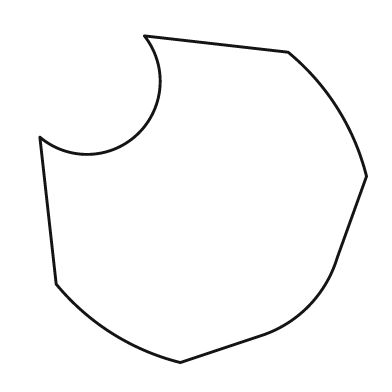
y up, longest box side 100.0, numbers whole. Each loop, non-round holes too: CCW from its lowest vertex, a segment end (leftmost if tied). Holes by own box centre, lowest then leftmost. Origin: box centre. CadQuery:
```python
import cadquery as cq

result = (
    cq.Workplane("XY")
    .moveTo(-7.0, -50.0)
    .lineTo(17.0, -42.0)
    .threePointArc((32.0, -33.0), (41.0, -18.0))
    .lineTo(50.0, 7.0)
    .threePointArc((41.0, 28.0), (26.0, 45.0))
    .lineTo(-18.0, 50.0)
    .threePointArc((-20.0, 20.0), (-50.0, 19.0))
    .lineTo(-45.0, -26.0)
    .threePointArc((-28.0, -41.0), (-7.0, -50.0))
    .close()
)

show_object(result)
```